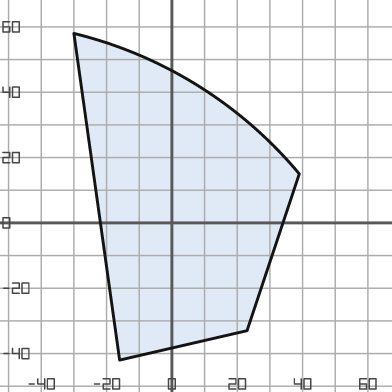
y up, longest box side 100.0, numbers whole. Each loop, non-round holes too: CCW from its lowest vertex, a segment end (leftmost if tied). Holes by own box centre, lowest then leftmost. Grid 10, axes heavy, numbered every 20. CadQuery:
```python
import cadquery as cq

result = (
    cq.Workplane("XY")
    .moveTo(-16.0, -42.0)
    .lineTo(23.0, -33.0)
    .lineTo(39.0, 15.0)
    .threePointArc((8.0, 42.0), (-30.0, 58.0))
    .close()
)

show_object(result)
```